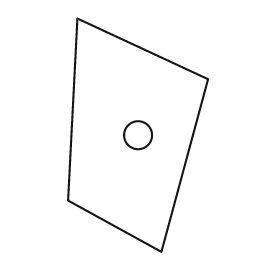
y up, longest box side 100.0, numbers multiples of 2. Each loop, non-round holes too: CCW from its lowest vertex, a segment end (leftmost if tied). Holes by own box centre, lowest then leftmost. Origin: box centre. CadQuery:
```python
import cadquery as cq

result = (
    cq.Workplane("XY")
    .moveTo(10.0, -50.0)
    .lineTo(30.0, 24.0)
    .lineTo(-26.0, 50.0)
    .lineTo(-30.0, -28.0)
    .close()
    .moveTo(0.0, 0.0)
    .circle(6.0)
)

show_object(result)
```